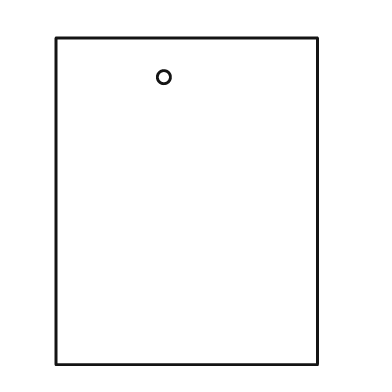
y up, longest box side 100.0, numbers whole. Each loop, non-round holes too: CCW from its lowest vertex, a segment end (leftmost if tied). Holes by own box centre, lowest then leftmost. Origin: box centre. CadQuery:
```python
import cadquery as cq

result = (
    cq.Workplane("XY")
    .moveTo(-40.0, -50.0)
    .lineTo(40.0, -50.0)
    .lineTo(40.0, 50.0)
    .lineTo(-40.0, 50.0)
    .close()
    .moveTo(-7.0, 38.0)
    .circle(2.0)
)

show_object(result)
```